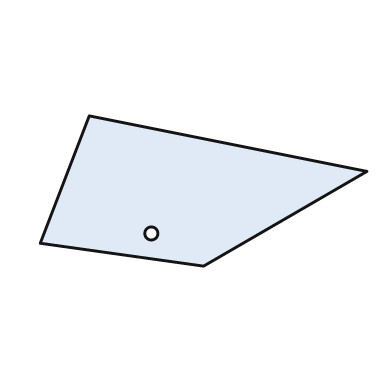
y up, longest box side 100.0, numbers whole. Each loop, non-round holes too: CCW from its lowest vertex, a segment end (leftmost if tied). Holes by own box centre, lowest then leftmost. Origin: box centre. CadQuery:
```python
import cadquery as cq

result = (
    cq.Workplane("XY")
    .moveTo(0.0, -23.0)
    .lineTo(50.0, 6.0)
    .lineTo(-35.0, 23.0)
    .lineTo(-50.0, -16.0)
    .close()
    .moveTo(-16.0, -13.0)
    .circle(2.0)
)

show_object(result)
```